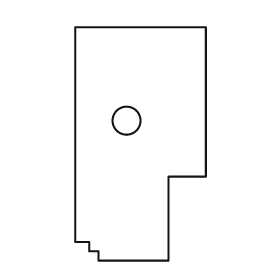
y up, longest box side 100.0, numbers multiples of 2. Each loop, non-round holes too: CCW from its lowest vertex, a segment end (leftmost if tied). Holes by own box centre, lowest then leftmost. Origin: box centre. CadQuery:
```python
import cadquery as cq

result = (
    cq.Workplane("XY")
    .moveTo(-18.0, -50.0)
    .lineTo(12.0, -50.0)
    .lineTo(12.0, -14.0)
    .lineTo(28.0, -14.0)
    .lineTo(28.0, 50.0)
    .lineTo(-28.0, 50.0)
    .lineTo(-28.0, -42.0)
    .lineTo(-22.0, -42.0)
    .lineTo(-22.0, -46.0)
    .lineTo(-18.0, -46.0)
    .close()
    .moveTo(-6.0, 10.0)
    .circle(6.0)
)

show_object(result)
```